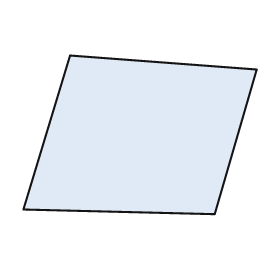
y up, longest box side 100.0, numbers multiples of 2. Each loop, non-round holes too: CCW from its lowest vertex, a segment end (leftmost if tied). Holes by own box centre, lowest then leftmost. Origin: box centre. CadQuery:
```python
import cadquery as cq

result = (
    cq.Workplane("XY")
    .moveTo(32.0, -34.0)
    .lineTo(50.0, 28.0)
    .lineTo(-30.0, 34.0)
    .lineTo(-50.0, -32.0)
    .close()
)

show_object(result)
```